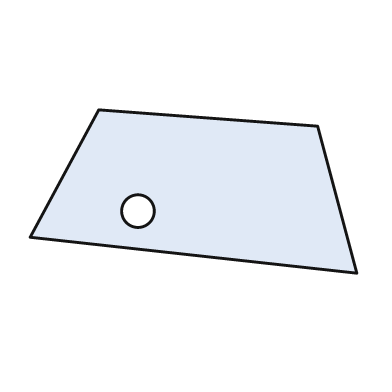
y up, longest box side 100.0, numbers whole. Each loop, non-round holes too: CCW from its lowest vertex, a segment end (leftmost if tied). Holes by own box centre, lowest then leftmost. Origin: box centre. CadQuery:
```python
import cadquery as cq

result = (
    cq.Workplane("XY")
    .moveTo(50.0, -25.0)
    .lineTo(38.0, 20.0)
    .lineTo(-29.0, 25.0)
    .lineTo(-50.0, -14.0)
    .close()
    .moveTo(-17.0, -6.0)
    .circle(5.0)
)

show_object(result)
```